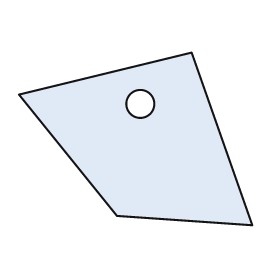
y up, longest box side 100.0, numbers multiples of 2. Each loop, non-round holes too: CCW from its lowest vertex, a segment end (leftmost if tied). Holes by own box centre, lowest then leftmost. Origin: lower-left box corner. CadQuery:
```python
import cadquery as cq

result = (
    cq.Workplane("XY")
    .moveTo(100.0, 0.0)
    .lineTo(74.0, 74.0)
    .lineTo(0.0, 56.0)
    .lineTo(42.0, 4.0)
    .close()
    .moveTo(52.0, 52.0)
    .circle(6.0)
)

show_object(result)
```